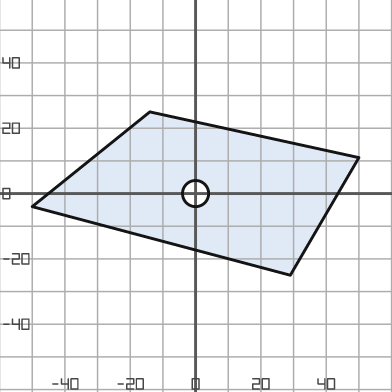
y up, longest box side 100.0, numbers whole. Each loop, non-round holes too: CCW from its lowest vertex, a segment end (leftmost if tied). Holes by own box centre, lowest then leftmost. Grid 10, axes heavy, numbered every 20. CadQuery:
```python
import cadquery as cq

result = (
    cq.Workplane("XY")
    .moveTo(29.0, -25.0)
    .lineTo(50.0, 11.0)
    .lineTo(-14.0, 25.0)
    .lineTo(-50.0, -4.0)
    .close()
    .moveTo(0.0, 0.0)
    .circle(4.0)
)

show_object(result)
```